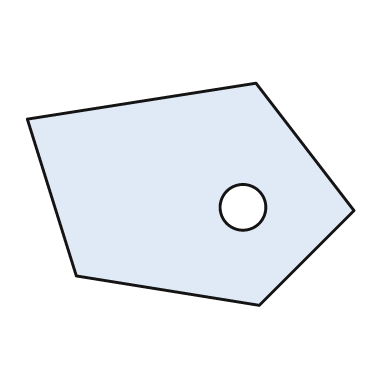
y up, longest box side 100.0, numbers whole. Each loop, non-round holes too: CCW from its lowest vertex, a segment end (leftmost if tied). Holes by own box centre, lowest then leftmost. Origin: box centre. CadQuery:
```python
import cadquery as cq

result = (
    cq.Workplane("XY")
    .moveTo(21.0, -34.0)
    .lineTo(50.0, -5.0)
    .lineTo(20.0, 34.0)
    .lineTo(-50.0, 23.0)
    .lineTo(-35.0, -25.0)
    .close()
    .moveTo(16.0, -4.0)
    .circle(7.0)
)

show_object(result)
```